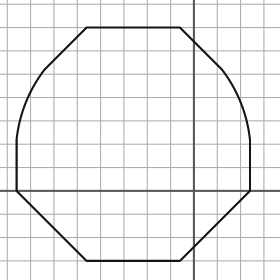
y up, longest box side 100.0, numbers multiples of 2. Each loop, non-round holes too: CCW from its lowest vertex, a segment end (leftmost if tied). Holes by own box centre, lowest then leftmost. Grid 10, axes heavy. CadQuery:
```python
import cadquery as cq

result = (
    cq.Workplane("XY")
    .moveTo(-46.0, -30.0)
    .lineTo(-6.0, -30.0)
    .lineTo(24.0, 0.0)
    .lineTo(24.0, 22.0)
    .threePointArc((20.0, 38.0), (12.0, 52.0))
    .lineTo(-6.0, 70.0)
    .lineTo(-46.0, 70.0)
    .lineTo(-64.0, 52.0)
    .threePointArc((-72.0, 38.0), (-76.0, 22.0))
    .lineTo(-76.0, 0.0)
    .close()
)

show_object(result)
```